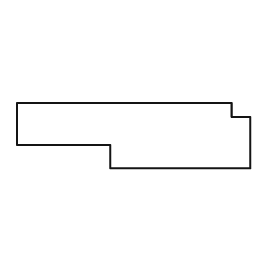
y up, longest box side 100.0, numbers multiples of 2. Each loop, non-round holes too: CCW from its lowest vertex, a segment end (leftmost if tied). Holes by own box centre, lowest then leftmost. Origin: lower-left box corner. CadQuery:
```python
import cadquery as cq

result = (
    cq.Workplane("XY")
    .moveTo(40.0, 0.0)
    .lineTo(100.0, 0.0)
    .lineTo(100.0, 22.0)
    .lineTo(92.0, 22.0)
    .lineTo(92.0, 28.0)
    .lineTo(0.0, 28.0)
    .lineTo(0.0, 10.0)
    .lineTo(40.0, 10.0)
    .close()
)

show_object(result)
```